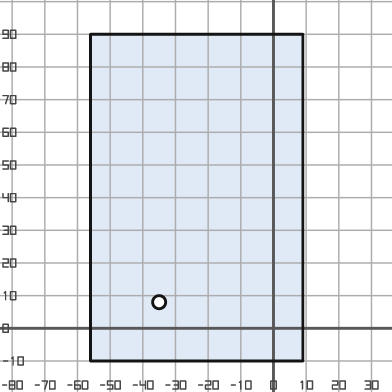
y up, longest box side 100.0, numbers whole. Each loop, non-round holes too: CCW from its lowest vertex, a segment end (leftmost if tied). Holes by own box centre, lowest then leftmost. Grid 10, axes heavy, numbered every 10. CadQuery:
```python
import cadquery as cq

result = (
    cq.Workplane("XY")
    .moveTo(-56.0, -10.0)
    .lineTo(9.0, -10.0)
    .lineTo(9.0, 90.0)
    .lineTo(-56.0, 90.0)
    .close()
    .moveTo(-35.0, 8.0)
    .circle(2.0)
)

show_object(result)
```